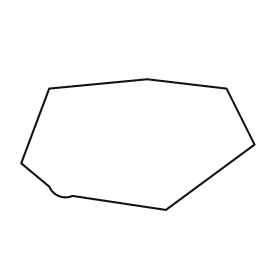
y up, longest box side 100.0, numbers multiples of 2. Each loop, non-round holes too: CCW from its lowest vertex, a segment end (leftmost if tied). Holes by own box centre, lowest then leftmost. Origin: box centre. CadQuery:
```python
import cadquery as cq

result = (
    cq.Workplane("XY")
    .moveTo(12.0, -28.0)
    .lineTo(50.0, 0.0)
    .lineTo(38.0, 24.0)
    .lineTo(4.0, 28.0)
    .lineTo(-38.0, 24.0)
    .lineTo(-50.0, -8.0)
    .lineTo(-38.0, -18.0)
    .threePointArc((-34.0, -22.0), (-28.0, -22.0))
    .close()
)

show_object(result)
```